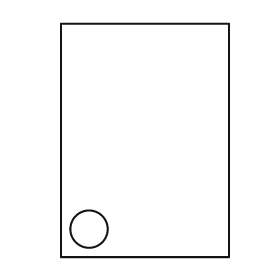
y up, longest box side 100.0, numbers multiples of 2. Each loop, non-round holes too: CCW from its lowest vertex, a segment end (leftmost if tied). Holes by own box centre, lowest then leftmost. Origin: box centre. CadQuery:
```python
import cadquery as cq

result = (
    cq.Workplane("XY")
    .moveTo(-36.0, -50.0)
    .lineTo(36.0, -50.0)
    .lineTo(36.0, 50.0)
    .lineTo(-36.0, 50.0)
    .close()
    .moveTo(-24.0, -38.0)
    .circle(8.0)
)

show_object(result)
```